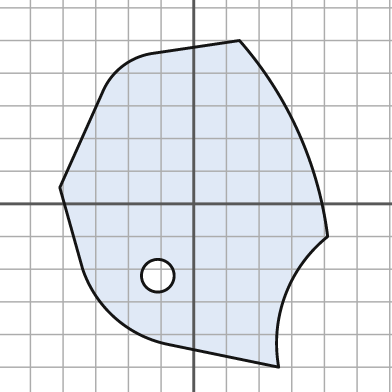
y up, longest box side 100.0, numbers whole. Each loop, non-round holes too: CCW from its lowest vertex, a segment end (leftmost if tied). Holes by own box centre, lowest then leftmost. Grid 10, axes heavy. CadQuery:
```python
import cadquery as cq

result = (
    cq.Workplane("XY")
    .moveTo(26.0, -50.0)
    .threePointArc((28.0, -28.0), (41.0, -10.0))
    .threePointArc((32.0, 22.0), (14.0, 50.0))
    .lineTo(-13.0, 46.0)
    .threePointArc((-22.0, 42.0), (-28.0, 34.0))
    .lineTo(-41.0, 5.0)
    .lineTo(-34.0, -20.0)
    .threePointArc((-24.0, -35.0), (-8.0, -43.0))
    .close()
    .moveTo(-11.0, -22.0)
    .circle(5.0)
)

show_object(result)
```